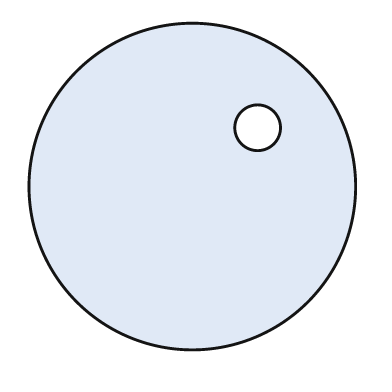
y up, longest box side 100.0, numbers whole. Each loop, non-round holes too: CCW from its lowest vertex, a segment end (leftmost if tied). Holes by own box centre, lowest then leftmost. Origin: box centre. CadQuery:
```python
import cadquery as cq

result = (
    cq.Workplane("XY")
    .moveTo(0.0, 0.0)
    .circle(50.0)
    .moveTo(20.0, 18.0)
    .circle(7.0)
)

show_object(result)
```